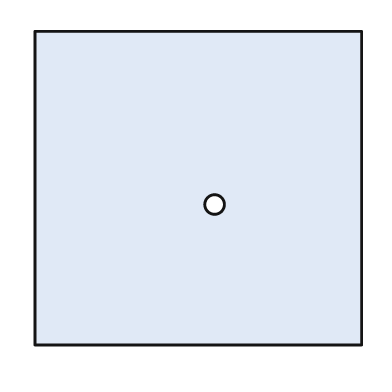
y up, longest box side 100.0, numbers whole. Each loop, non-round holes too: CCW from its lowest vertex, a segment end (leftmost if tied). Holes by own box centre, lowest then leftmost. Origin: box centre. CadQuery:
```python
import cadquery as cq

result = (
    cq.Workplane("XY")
    .moveTo(-50.0, -48.0)
    .lineTo(50.0, -48.0)
    .lineTo(50.0, 48.0)
    .lineTo(-50.0, 48.0)
    .close()
    .moveTo(5.0, -5.0)
    .circle(3.0)
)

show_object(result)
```